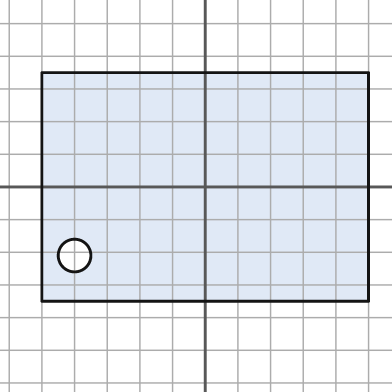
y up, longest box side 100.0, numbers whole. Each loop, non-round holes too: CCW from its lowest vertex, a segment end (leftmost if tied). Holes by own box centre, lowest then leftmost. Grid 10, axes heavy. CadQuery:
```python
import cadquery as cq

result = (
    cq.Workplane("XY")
    .moveTo(-50.0, -35.0)
    .lineTo(50.0, -35.0)
    .lineTo(50.0, 35.0)
    .lineTo(-50.0, 35.0)
    .close()
    .moveTo(-40.0, -21.0)
    .circle(5.0)
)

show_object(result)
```